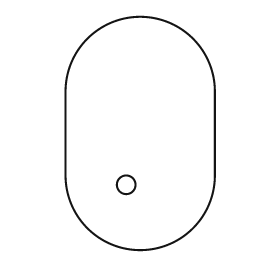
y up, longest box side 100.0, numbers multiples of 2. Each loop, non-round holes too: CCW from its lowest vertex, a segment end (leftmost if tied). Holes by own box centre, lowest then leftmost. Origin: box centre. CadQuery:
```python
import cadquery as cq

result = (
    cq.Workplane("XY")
    .moveTo(-32.0, -18.0)
    .threePointArc((0.0, -50.0), (32.0, -18.0))
    .lineTo(32.0, 18.0)
    .threePointArc((0.0, 50.0), (-32.0, 18.0))
    .close()
    .moveTo(-6.0, -22.0)
    .circle(4.0)
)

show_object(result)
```